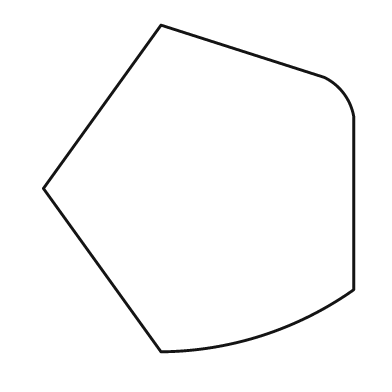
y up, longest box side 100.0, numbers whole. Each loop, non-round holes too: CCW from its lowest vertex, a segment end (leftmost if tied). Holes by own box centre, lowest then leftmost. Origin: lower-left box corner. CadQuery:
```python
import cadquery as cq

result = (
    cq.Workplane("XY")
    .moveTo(36.0, 0.0)
    .threePointArc((67.0, 5.0), (95.0, 19.0))
    .lineTo(95.0, 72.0)
    .threePointArc((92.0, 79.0), (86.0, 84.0))
    .lineTo(36.0, 100.0)
    .lineTo(0.0, 50.0)
    .close()
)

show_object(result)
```